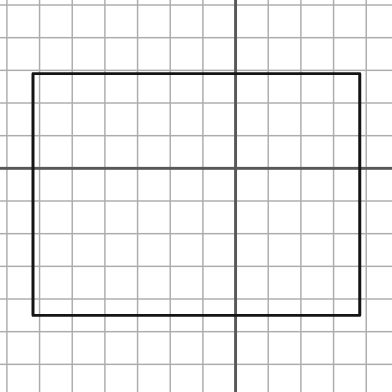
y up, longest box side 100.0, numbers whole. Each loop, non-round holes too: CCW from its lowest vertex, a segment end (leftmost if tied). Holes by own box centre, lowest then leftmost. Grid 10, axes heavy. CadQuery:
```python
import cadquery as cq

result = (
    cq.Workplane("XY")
    .moveTo(-62.0, -45.0)
    .lineTo(38.0, -45.0)
    .lineTo(38.0, 29.0)
    .lineTo(-62.0, 29.0)
    .close()
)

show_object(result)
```